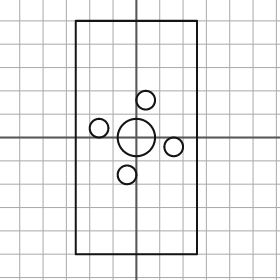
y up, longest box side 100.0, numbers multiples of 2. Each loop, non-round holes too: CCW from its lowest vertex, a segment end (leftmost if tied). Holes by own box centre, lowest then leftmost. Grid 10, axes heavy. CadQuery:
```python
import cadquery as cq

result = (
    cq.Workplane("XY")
    .moveTo(-26.0, -50.0)
    .lineTo(26.0, -50.0)
    .lineTo(26.0, 50.0)
    .lineTo(-26.0, 50.0)
    .close()
    .moveTo(-4.0, -16.0)
    .circle(4.0)
    .moveTo(16.0, -4.0)
    .circle(4.0)
    .moveTo(0.0, 0.0)
    .circle(8.0)
    .moveTo(-16.0, 4.0)
    .circle(4.0)
    .moveTo(4.0, 16.0)
    .circle(4.0)
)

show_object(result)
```